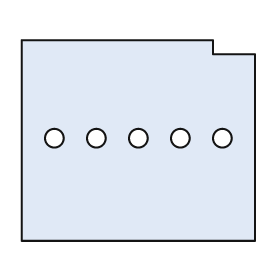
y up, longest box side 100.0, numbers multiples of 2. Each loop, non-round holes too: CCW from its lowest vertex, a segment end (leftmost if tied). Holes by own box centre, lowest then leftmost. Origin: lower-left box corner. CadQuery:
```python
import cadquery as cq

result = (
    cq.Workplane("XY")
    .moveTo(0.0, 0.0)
    .lineTo(100.0, 0.0)
    .lineTo(100.0, 80.0)
    .lineTo(82.0, 80.0)
    .lineTo(82.0, 86.0)
    .lineTo(0.0, 86.0)
    .close()
    .moveTo(14.0, 44.0)
    .circle(4.0)
    .moveTo(32.0, 44.0)
    .circle(4.0)
    .moveTo(50.0, 44.0)
    .circle(4.0)
    .moveTo(68.0, 44.0)
    .circle(4.0)
    .moveTo(86.0, 44.0)
    .circle(4.0)
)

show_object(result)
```